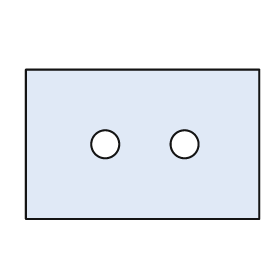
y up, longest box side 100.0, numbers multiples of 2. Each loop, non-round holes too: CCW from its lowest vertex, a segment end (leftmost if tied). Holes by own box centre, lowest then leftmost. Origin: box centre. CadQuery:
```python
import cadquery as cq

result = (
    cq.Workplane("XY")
    .moveTo(-50.0, -32.0)
    .lineTo(50.0, -32.0)
    .lineTo(50.0, 32.0)
    .lineTo(-50.0, 32.0)
    .close()
    .moveTo(-16.0, 0.0)
    .circle(6.0)
    .moveTo(18.0, 0.0)
    .circle(6.0)
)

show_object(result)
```